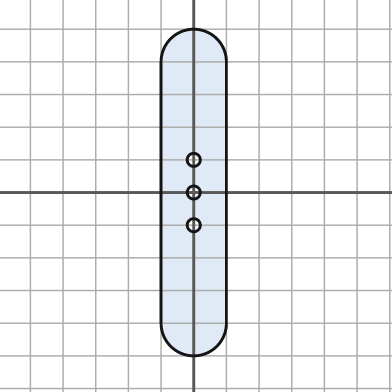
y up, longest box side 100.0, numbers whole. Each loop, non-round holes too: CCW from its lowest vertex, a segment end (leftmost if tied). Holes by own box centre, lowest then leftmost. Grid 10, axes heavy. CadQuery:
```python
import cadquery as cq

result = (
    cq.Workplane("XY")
    .moveTo(-10.0, -40.0)
    .threePointArc((0.0, -50.0), (10.0, -40.0))
    .lineTo(10.0, 40.0)
    .threePointArc((0.0, 50.0), (-10.0, 40.0))
    .close()
    .moveTo(0.0, -10.0)
    .circle(2.0)
    .moveTo(0.0, 0.0)
    .circle(2.0)
    .moveTo(0.0, 10.0)
    .circle(2.0)
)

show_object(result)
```